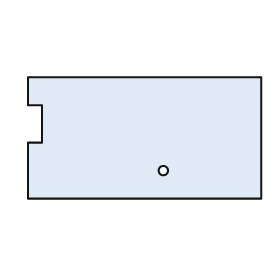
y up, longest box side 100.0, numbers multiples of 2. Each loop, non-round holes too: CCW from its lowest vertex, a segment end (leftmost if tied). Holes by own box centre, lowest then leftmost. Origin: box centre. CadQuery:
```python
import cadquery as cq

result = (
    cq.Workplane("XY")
    .moveTo(-50.0, -26.0)
    .lineTo(50.0, -26.0)
    .lineTo(50.0, 26.0)
    .lineTo(-50.0, 26.0)
    .lineTo(-50.0, 14.0)
    .lineTo(-44.0, 14.0)
    .lineTo(-44.0, -2.0)
    .lineTo(-50.0, -2.0)
    .close()
    .moveTo(8.0, -14.0)
    .circle(2.0)
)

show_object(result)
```